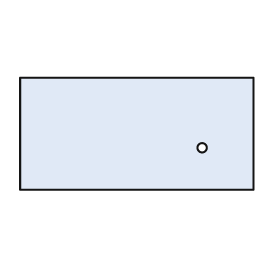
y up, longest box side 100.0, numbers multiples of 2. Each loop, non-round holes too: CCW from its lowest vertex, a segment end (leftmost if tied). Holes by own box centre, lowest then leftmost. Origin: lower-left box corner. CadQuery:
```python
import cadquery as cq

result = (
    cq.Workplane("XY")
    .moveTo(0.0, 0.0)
    .lineTo(100.0, 0.0)
    .lineTo(100.0, 48.0)
    .lineTo(0.0, 48.0)
    .close()
    .moveTo(78.0, 18.0)
    .circle(2.0)
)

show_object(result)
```